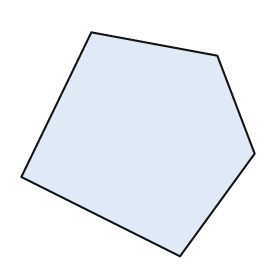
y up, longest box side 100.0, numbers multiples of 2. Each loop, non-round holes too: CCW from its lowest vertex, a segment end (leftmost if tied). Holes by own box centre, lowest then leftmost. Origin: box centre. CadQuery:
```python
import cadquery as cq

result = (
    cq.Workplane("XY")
    .moveTo(18.0, -48.0)
    .lineTo(50.0, -4.0)
    .lineTo(34.0, 38.0)
    .lineTo(-20.0, 48.0)
    .lineTo(-50.0, -14.0)
    .close()
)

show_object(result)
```